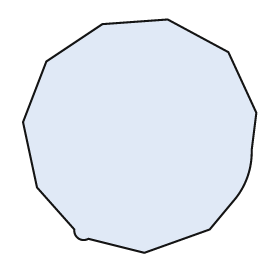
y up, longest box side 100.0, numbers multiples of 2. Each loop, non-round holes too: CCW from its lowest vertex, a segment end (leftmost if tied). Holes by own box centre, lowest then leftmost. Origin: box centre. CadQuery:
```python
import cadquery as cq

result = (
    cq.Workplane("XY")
    .moveTo(2.0, -50.0)
    .lineTo(30.0, -40.0)
    .lineTo(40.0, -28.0)
    .threePointArc((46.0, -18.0), (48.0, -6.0))
    .lineTo(50.0, 10.0)
    .lineTo(38.0, 36.0)
    .lineTo(12.0, 50.0)
    .lineTo(-16.0, 48.0)
    .lineTo(-40.0, 32.0)
    .lineTo(-50.0, 6.0)
    .lineTo(-44.0, -22.0)
    .lineTo(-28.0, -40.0)
    .threePointArc((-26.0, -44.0), (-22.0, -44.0))
    .close()
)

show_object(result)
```